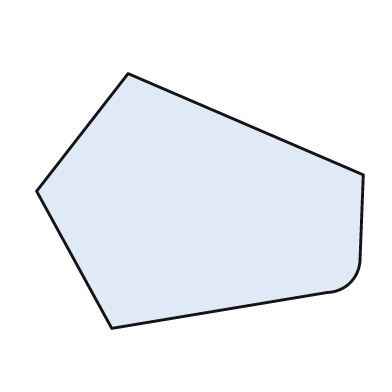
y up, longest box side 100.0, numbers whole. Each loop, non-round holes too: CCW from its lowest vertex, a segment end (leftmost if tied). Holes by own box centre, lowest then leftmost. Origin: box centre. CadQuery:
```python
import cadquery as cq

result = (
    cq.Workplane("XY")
    .moveTo(-27.0, -39.0)
    .lineTo(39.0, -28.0)
    .threePointArc((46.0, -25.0), (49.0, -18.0))
    .lineTo(50.0, 8.0)
    .lineTo(-22.0, 39.0)
    .lineTo(-50.0, 3.0)
    .close()
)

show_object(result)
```